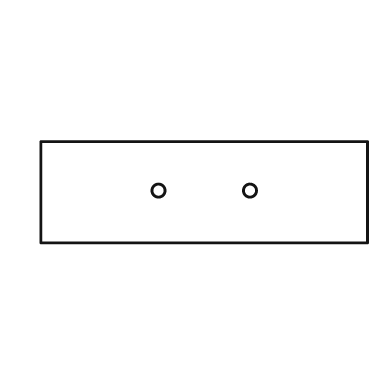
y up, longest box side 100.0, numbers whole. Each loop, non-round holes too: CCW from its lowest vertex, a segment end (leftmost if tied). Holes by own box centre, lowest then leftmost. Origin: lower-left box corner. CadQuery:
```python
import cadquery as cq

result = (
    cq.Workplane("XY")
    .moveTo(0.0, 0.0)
    .lineTo(100.0, 0.0)
    .lineTo(100.0, 31.0)
    .lineTo(0.0, 31.0)
    .close()
    .moveTo(36.0, 16.0)
    .circle(2.0)
    .moveTo(64.0, 16.0)
    .circle(2.0)
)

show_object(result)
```